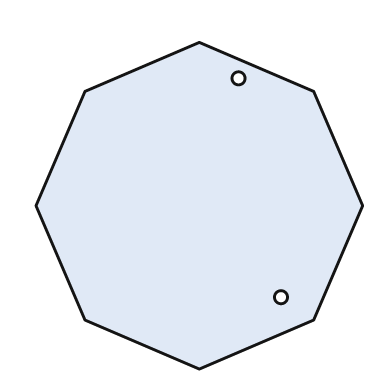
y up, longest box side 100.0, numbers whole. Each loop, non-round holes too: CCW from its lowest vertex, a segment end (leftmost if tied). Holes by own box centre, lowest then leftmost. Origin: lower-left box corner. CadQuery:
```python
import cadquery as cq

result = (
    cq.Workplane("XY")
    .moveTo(50.0, 0.0)
    .lineTo(85.0, 15.0)
    .lineTo(100.0, 50.0)
    .lineTo(85.0, 85.0)
    .lineTo(50.0, 100.0)
    .lineTo(15.0, 85.0)
    .lineTo(0.0, 50.0)
    .lineTo(15.0, 15.0)
    .close()
    .moveTo(75.0, 22.0)
    .circle(2.0)
    .moveTo(62.0, 89.0)
    .circle(2.0)
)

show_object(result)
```